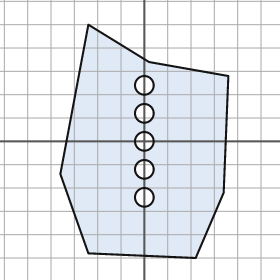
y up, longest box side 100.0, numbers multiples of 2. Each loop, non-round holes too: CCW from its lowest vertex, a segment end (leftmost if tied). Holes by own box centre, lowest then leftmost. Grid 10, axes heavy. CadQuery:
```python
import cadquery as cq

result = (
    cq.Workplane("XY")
    .moveTo(22.0, -50.0)
    .lineTo(34.0, -22.0)
    .lineTo(36.0, 28.0)
    .lineTo(2.0, 34.0)
    .lineTo(-24.0, 50.0)
    .lineTo(-36.0, -14.0)
    .lineTo(-24.0, -48.0)
    .close()
    .moveTo(0.0, -24.0)
    .circle(4.0)
    .moveTo(0.0, -12.0)
    .circle(4.0)
    .moveTo(0.0, 0.0)
    .circle(4.0)
    .moveTo(0.0, 12.0)
    .circle(4.0)
    .moveTo(0.0, 24.0)
    .circle(4.0)
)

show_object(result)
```